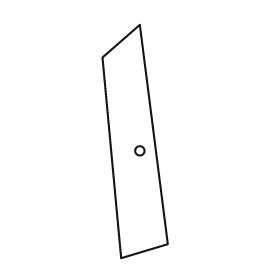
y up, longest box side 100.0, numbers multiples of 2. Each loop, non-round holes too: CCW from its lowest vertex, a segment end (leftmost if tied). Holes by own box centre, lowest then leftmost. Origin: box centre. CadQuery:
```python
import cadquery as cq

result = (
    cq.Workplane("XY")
    .moveTo(-6.0, -50.0)
    .lineTo(14.0, -44.0)
    .lineTo(2.0, 50.0)
    .lineTo(-14.0, 36.0)
    .close()
    .moveTo(2.0, -4.0)
    .circle(2.0)
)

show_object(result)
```